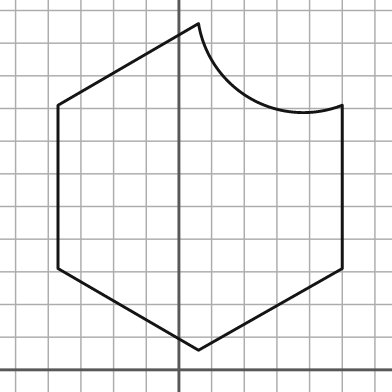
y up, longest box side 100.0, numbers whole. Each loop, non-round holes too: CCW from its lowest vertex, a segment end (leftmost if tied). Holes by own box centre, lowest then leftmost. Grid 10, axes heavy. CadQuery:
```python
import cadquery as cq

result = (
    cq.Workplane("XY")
    .moveTo(6.0, 6.0)
    .lineTo(50.0, 31.0)
    .lineTo(50.0, 81.0)
    .threePointArc((22.0, 83.0), (6.0, 106.0))
    .lineTo(-37.0, 81.0)
    .lineTo(-37.0, 31.0)
    .close()
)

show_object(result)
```